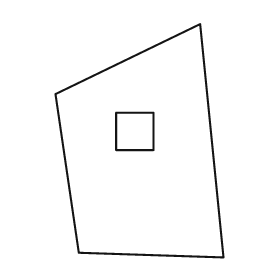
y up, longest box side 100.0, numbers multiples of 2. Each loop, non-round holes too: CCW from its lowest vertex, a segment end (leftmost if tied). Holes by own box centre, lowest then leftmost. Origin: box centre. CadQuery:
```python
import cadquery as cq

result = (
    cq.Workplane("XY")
    .moveTo(36.0, -50.0)
    .lineTo(26.0, 50.0)
    .lineTo(-36.0, 20.0)
    .lineTo(-26.0, -48.0)
    .close()
    .moveTo(-10.0, -4.0)
    .lineTo(6.0, -4.0)
    .lineTo(6.0, 12.0)
    .lineTo(-10.0, 12.0)
    .close()
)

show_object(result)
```